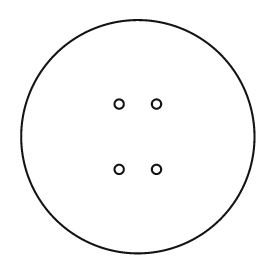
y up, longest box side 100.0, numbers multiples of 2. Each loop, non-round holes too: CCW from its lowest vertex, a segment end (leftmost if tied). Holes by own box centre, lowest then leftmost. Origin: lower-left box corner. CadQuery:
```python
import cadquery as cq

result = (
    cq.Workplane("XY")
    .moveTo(50.0, 50.0)
    .circle(50.0)
    .moveTo(42.0, 36.0)
    .circle(2.0)
    .moveTo(58.0, 36.0)
    .circle(2.0)
    .moveTo(42.0, 64.0)
    .circle(2.0)
    .moveTo(58.0, 64.0)
    .circle(2.0)
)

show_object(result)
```